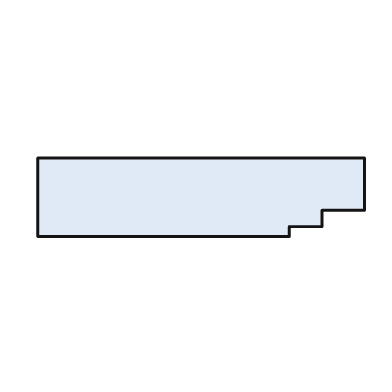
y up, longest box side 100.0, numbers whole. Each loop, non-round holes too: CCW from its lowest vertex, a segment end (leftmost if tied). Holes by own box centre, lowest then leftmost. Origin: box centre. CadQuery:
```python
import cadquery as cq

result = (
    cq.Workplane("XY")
    .moveTo(-50.0, -12.0)
    .lineTo(27.0, -12.0)
    .lineTo(27.0, -9.0)
    .lineTo(37.0, -9.0)
    .lineTo(37.0, -4.0)
    .lineTo(50.0, -4.0)
    .lineTo(50.0, 12.0)
    .lineTo(-50.0, 12.0)
    .close()
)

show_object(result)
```